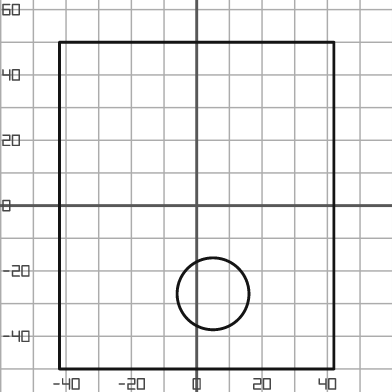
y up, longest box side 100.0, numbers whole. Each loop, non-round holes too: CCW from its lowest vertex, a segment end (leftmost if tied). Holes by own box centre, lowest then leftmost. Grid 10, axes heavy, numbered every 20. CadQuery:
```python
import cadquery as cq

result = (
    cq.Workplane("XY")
    .moveTo(-42.0, -50.0)
    .lineTo(42.0, -50.0)
    .lineTo(42.0, 50.0)
    .lineTo(-42.0, 50.0)
    .close()
    .moveTo(5.0, -27.0)
    .circle(11.0)
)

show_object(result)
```